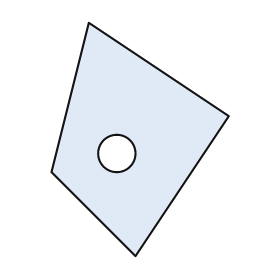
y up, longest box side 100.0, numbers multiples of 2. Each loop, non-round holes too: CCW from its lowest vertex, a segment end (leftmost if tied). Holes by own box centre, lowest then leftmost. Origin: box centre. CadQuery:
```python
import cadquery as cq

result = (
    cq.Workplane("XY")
    .moveTo(-2.0, -50.0)
    .lineTo(38.0, 10.0)
    .lineTo(-22.0, 50.0)
    .lineTo(-38.0, -14.0)
    .close()
    .moveTo(-10.0, -6.0)
    .circle(8.0)
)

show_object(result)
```